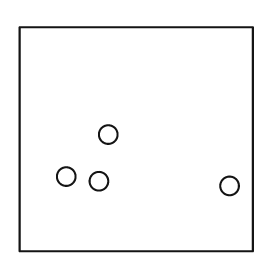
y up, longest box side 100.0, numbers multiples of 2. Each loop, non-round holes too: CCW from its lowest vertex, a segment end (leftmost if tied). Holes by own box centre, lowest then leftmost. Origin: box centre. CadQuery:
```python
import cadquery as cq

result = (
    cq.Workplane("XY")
    .moveTo(-50.0, -48.0)
    .lineTo(50.0, -48.0)
    .lineTo(50.0, 48.0)
    .lineTo(-50.0, 48.0)
    .close()
    .moveTo(40.0, -20.0)
    .circle(4.0)
    .moveTo(-16.0, -18.0)
    .circle(4.0)
    .moveTo(-30.0, -16.0)
    .circle(4.0)
    .moveTo(-12.0, 2.0)
    .circle(4.0)
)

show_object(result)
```